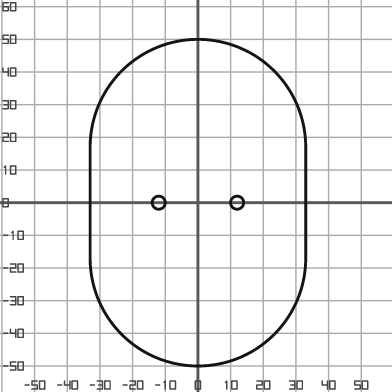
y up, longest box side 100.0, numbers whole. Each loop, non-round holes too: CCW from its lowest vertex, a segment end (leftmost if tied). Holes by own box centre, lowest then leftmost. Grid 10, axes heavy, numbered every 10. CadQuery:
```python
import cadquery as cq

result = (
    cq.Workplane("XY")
    .moveTo(-33.0, -17.0)
    .threePointArc((0.0, -50.0), (33.0, -17.0))
    .lineTo(33.0, 17.0)
    .threePointArc((0.0, 50.0), (-33.0, 17.0))
    .close()
    .moveTo(-12.0, 0.0)
    .circle(2.0)
    .moveTo(12.0, 0.0)
    .circle(2.0)
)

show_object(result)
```